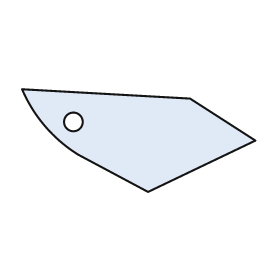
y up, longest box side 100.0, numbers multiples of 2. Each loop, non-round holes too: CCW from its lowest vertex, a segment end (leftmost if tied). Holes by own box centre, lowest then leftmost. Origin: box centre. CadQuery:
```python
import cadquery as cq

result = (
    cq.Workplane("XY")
    .moveTo(4.0, -22.0)
    .lineTo(50.0, 0.0)
    .lineTo(22.0, 18.0)
    .lineTo(-50.0, 22.0)
    .threePointArc((-40.0, 6.0), (-26.0, -6.0))
    .close()
    .moveTo(-28.0, 8.0)
    .circle(4.0)
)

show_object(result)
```